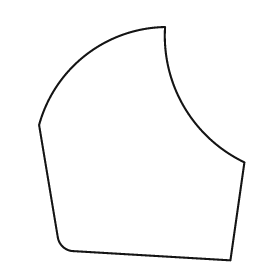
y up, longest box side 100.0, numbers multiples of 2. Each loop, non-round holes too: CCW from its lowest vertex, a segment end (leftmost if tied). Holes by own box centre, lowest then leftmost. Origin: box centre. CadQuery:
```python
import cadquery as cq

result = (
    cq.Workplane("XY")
    .moveTo(38.0, -50.0)
    .lineTo(44.0, -8.0)
    .threePointArc((18.0, 16.0), (10.0, 50.0))
    .threePointArc((-24.0, 38.0), (-44.0, 8.0))
    .lineTo(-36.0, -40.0)
    .threePointArc((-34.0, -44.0), (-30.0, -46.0))
    .close()
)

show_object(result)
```